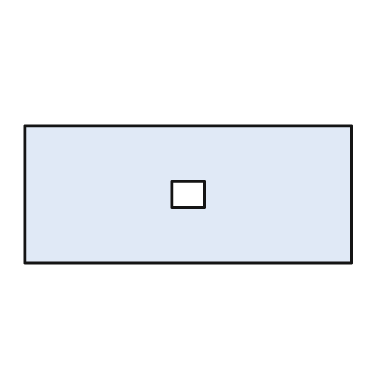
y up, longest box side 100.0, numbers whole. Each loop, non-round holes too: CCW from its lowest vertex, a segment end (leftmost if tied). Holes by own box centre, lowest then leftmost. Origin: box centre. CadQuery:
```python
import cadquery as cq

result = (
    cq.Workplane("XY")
    .moveTo(-50.0, -21.0)
    .lineTo(50.0, -21.0)
    .lineTo(50.0, 21.0)
    .lineTo(-50.0, 21.0)
    .close()
    .moveTo(-5.0, -4.0)
    .lineTo(5.0, -4.0)
    .lineTo(5.0, 4.0)
    .lineTo(-5.0, 4.0)
    .close()
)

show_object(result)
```